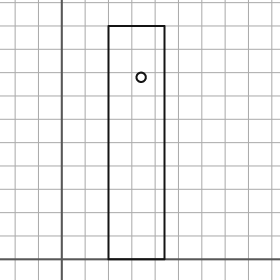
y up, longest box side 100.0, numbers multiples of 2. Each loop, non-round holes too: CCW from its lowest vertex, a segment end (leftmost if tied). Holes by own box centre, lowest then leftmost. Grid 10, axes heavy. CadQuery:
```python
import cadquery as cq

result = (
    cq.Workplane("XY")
    .moveTo(20.0, 0.0)
    .lineTo(44.0, 0.0)
    .lineTo(44.0, 100.0)
    .lineTo(20.0, 100.0)
    .close()
    .moveTo(34.0, 78.0)
    .circle(2.0)
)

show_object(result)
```